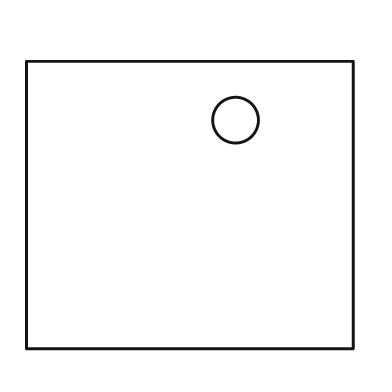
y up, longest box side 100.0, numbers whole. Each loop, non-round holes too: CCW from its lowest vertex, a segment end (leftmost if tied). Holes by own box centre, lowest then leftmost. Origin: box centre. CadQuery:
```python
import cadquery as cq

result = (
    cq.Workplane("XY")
    .moveTo(-50.0, -44.0)
    .lineTo(50.0, -44.0)
    .lineTo(50.0, 44.0)
    .lineTo(-50.0, 44.0)
    .close()
    .moveTo(14.0, 26.0)
    .circle(7.0)
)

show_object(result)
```